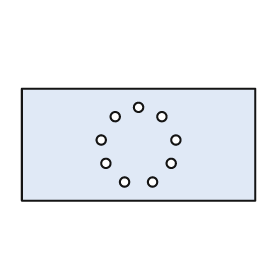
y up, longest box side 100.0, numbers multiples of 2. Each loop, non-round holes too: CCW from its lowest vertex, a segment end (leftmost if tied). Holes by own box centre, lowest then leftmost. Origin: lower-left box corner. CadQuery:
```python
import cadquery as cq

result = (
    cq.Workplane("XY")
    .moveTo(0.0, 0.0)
    .lineTo(100.0, 0.0)
    .lineTo(100.0, 48.0)
    .lineTo(0.0, 48.0)
    .close()
    .moveTo(44.0, 8.0)
    .circle(2.0)
    .moveTo(56.0, 8.0)
    .circle(2.0)
    .moveTo(36.0, 16.0)
    .circle(2.0)
    .moveTo(64.0, 16.0)
    .circle(2.0)
    .moveTo(34.0, 26.0)
    .circle(2.0)
    .moveTo(66.0, 26.0)
    .circle(2.0)
    .moveTo(40.0, 36.0)
    .circle(2.0)
    .moveTo(60.0, 36.0)
    .circle(2.0)
    .moveTo(50.0, 40.0)
    .circle(2.0)
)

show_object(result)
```